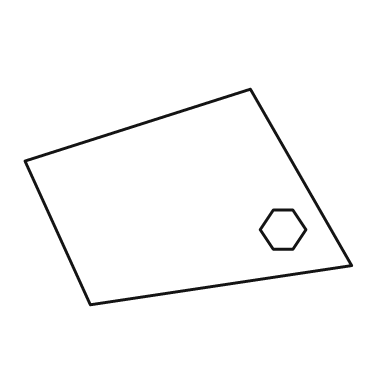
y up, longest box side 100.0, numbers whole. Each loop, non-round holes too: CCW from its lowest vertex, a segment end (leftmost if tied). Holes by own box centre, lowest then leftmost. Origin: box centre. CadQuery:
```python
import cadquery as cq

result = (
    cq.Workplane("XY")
    .moveTo(-30.0, -33.0)
    .lineTo(50.0, -21.0)
    .lineTo(19.0, 33.0)
    .lineTo(-50.0, 11.0)
    .close()
    .moveTo(26.0, -16.0)
    .lineTo(32.0, -16.0)
    .lineTo(36.0, -10.0)
    .lineTo(32.0, -4.0)
    .lineTo(26.0, -4.0)
    .lineTo(22.0, -10.0)
    .close()
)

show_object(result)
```